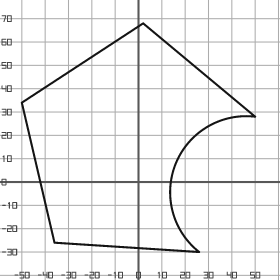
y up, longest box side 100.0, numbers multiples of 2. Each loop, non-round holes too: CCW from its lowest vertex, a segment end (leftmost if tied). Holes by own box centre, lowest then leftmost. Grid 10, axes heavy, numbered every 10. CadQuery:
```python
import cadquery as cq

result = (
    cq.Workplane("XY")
    .moveTo(26.0, -30.0)
    .threePointArc((16.0, 8.0), (50.0, 28.0))
    .lineTo(2.0, 68.0)
    .lineTo(-50.0, 34.0)
    .lineTo(-36.0, -26.0)
    .close()
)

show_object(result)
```